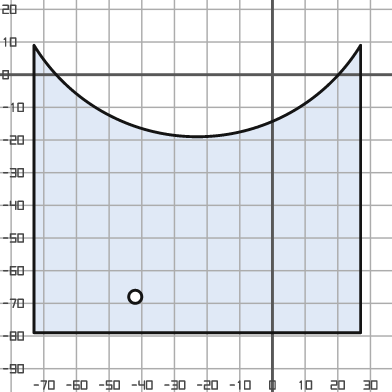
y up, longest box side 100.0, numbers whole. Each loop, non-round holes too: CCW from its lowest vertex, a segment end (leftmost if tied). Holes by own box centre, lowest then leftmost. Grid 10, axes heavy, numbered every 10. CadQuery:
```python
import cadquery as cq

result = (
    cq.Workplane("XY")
    .moveTo(-73.0, -79.0)
    .lineTo(27.0, -79.0)
    .lineTo(27.0, 9.0)
    .threePointArc((-23.0, -19.0), (-73.0, 9.0))
    .close()
    .moveTo(-42.0, -68.0)
    .circle(2.0)
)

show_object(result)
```